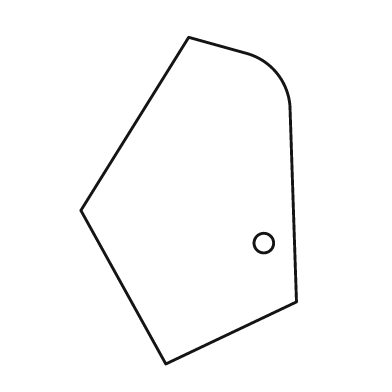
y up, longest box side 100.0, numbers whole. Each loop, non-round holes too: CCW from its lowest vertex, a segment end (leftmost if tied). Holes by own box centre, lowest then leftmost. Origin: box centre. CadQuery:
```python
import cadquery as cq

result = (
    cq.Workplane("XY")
    .moveTo(-7.0, -50.0)
    .lineTo(33.0, -31.0)
    .lineTo(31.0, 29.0)
    .threePointArc((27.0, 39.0), (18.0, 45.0))
    .lineTo(0.0, 50.0)
    .lineTo(-33.0, -3.0)
    .close()
    .moveTo(23.0, -13.0)
    .circle(3.0)
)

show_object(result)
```